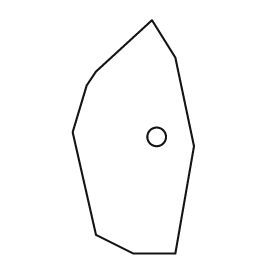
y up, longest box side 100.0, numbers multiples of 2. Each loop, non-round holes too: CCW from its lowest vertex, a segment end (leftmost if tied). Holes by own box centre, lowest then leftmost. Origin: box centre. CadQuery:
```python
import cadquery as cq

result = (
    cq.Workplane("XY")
    .moveTo(0.0, -50.0)
    .lineTo(18.0, -50.0)
    .lineTo(26.0, -4.0)
    .lineTo(18.0, 34.0)
    .lineTo(8.0, 50.0)
    .lineTo(-16.0, 28.0)
    .lineTo(-20.0, 22.0)
    .lineTo(-26.0, 2.0)
    .lineTo(-16.0, -42.0)
    .close()
    .moveTo(10.0, 0.0)
    .circle(4.0)
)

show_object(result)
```